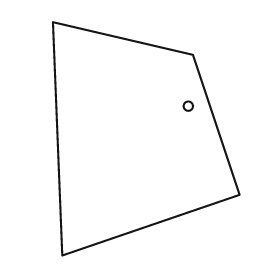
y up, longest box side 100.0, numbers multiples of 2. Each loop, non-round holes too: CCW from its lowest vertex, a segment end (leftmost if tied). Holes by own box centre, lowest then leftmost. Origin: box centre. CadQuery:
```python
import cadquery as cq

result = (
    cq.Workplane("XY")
    .moveTo(-36.0, -50.0)
    .lineTo(40.0, -24.0)
    .lineTo(20.0, 36.0)
    .lineTo(-40.0, 50.0)
    .close()
    .moveTo(18.0, 14.0)
    .circle(2.0)
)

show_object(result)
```